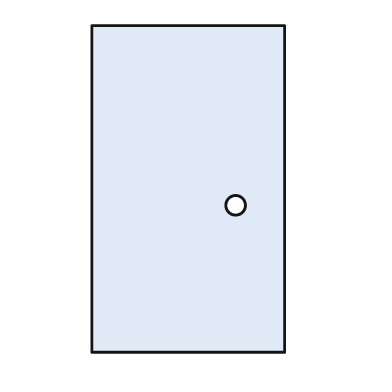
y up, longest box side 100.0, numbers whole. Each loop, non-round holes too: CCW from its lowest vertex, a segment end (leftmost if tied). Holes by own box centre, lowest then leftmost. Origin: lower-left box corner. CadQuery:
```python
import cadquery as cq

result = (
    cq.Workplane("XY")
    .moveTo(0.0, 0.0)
    .lineTo(59.0, 0.0)
    .lineTo(59.0, 100.0)
    .lineTo(0.0, 100.0)
    .close()
    .moveTo(44.0, 45.0)
    .circle(3.0)
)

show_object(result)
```